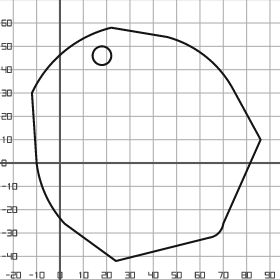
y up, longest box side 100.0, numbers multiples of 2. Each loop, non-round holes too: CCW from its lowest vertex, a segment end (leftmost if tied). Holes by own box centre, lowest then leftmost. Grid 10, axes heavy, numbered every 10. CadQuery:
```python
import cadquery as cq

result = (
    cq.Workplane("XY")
    .moveTo(24.0, -42.0)
    .lineTo(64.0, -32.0)
    .threePointArc((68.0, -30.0), (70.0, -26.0))
    .lineTo(86.0, 10.0)
    .lineTo(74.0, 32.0)
    .threePointArc((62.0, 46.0), (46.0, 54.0))
    .lineTo(22.0, 58.0)
    .threePointArc((2.0, 48.0), (-12.0, 30.0))
    .lineTo(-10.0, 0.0)
    .threePointArc((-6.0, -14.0), (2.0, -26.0))
    .close()
    .moveTo(18.0, 46.0)
    .circle(4.0)
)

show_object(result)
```